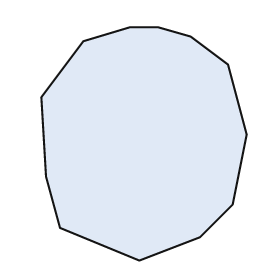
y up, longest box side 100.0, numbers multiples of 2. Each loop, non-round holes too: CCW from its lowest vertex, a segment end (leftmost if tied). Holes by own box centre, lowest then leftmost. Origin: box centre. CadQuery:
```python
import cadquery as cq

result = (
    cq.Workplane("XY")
    .moveTo(-2.0, -50.0)
    .lineTo(24.0, -40.0)
    .lineTo(38.0, -26.0)
    .lineTo(44.0, 4.0)
    .lineTo(36.0, 34.0)
    .lineTo(20.0, 46.0)
    .lineTo(6.0, 50.0)
    .lineTo(-6.0, 50.0)
    .lineTo(-26.0, 44.0)
    .lineTo(-44.0, 20.0)
    .lineTo(-42.0, -14.0)
    .lineTo(-36.0, -36.0)
    .close()
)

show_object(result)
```